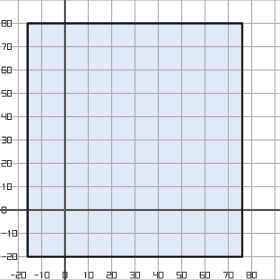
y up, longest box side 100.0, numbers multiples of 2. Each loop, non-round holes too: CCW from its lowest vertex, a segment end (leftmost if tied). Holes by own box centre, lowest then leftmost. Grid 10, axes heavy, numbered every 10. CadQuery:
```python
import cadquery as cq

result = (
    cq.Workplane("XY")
    .moveTo(-16.0, -20.0)
    .lineTo(76.0, -20.0)
    .lineTo(76.0, 80.0)
    .lineTo(-16.0, 80.0)
    .close()
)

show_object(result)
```